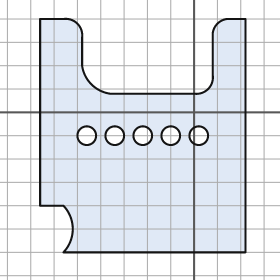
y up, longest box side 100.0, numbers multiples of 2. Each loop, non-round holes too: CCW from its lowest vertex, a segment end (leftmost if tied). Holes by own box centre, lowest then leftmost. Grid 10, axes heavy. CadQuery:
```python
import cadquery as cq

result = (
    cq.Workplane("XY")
    .moveTo(-56.0, -60.0)
    .lineTo(22.0, -60.0)
    .lineTo(22.0, 40.0)
    .lineTo(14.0, 40.0)
    .threePointArc((10.0, 38.0), (8.0, 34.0))
    .lineTo(8.0, 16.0)
    .threePointArc((6.0, 10.0), (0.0, 8.0))
    .lineTo(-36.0, 8.0)
    .threePointArc((-44.0, 12.0), (-48.0, 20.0))
    .lineTo(-48.0, 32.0)
    .threePointArc((-50.0, 38.0), (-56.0, 40.0))
    .lineTo(-66.0, 40.0)
    .lineTo(-66.0, -40.0)
    .lineTo(-56.0, -40.0)
    .threePointArc((-52.0, -50.0), (-56.0, -60.0))
    .close()
    .moveTo(-46.0, -10.0)
    .circle(4.0)
    .moveTo(-34.0, -10.0)
    .circle(4.0)
    .moveTo(-22.0, -10.0)
    .circle(4.0)
    .moveTo(-10.0, -10.0)
    .circle(4.0)
    .moveTo(2.0, -10.0)
    .circle(4.0)
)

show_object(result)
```